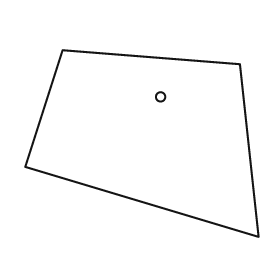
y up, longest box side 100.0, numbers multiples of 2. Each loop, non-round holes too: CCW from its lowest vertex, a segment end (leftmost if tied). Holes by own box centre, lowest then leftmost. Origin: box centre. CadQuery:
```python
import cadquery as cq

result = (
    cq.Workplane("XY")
    .moveTo(50.0, -40.0)
    .lineTo(42.0, 34.0)
    .lineTo(-34.0, 40.0)
    .lineTo(-50.0, -10.0)
    .close()
    .moveTo(8.0, 20.0)
    .circle(2.0)
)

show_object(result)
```